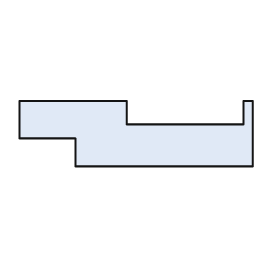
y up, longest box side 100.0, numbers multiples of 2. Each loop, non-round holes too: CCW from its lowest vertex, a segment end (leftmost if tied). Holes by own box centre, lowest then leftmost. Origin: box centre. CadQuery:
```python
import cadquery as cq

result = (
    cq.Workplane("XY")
    .moveTo(-26.0, -14.0)
    .lineTo(50.0, -14.0)
    .lineTo(50.0, 14.0)
    .lineTo(46.0, 14.0)
    .lineTo(46.0, 4.0)
    .lineTo(-4.0, 4.0)
    .lineTo(-4.0, 14.0)
    .lineTo(-50.0, 14.0)
    .lineTo(-50.0, -2.0)
    .lineTo(-26.0, -2.0)
    .close()
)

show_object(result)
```